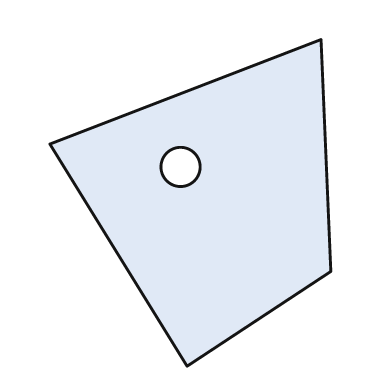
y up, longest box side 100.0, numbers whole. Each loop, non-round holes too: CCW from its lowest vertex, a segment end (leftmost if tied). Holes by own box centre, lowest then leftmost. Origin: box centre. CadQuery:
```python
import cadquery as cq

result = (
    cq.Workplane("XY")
    .moveTo(-1.0, -50.0)
    .lineTo(43.0, -21.0)
    .lineTo(40.0, 50.0)
    .lineTo(-43.0, 18.0)
    .close()
    .moveTo(-3.0, 11.0)
    .circle(6.0)
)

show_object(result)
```